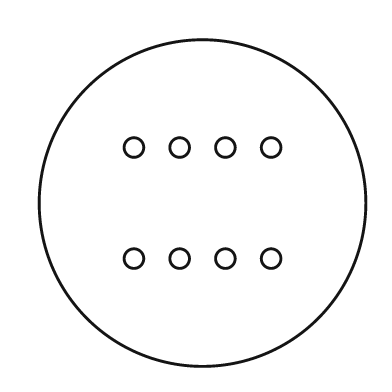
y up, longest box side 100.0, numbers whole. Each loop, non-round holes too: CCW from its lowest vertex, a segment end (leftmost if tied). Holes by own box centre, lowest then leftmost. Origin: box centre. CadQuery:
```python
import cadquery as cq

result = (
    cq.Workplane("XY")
    .moveTo(0.0, 0.0)
    .circle(50.0)
    .moveTo(-21.0, -17.0)
    .circle(3.0)
    .moveTo(-7.0, -17.0)
    .circle(3.0)
    .moveTo(7.0, -17.0)
    .circle(3.0)
    .moveTo(21.0, -17.0)
    .circle(3.0)
    .moveTo(-21.0, 17.0)
    .circle(3.0)
    .moveTo(-7.0, 17.0)
    .circle(3.0)
    .moveTo(7.0, 17.0)
    .circle(3.0)
    .moveTo(21.0, 17.0)
    .circle(3.0)
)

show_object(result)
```